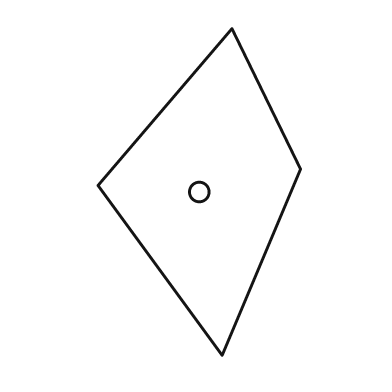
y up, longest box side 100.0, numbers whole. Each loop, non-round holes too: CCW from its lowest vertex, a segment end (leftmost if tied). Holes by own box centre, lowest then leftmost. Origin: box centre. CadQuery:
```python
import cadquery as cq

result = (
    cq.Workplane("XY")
    .moveTo(7.0, -50.0)
    .lineTo(31.0, 7.0)
    .lineTo(10.0, 50.0)
    .lineTo(-31.0, 2.0)
    .close()
    .moveTo(0.0, 0.0)
    .circle(3.0)
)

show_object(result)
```